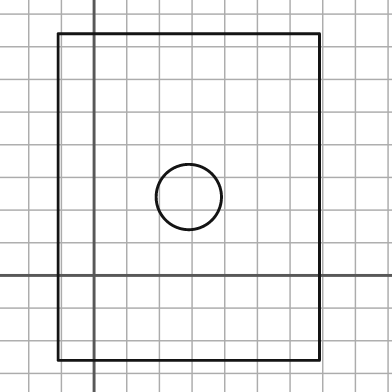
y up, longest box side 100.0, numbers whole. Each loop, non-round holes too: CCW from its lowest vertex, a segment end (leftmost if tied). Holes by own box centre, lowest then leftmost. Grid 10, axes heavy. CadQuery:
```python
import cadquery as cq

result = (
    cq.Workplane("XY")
    .moveTo(-11.0, -26.0)
    .lineTo(69.0, -26.0)
    .lineTo(69.0, 74.0)
    .lineTo(-11.0, 74.0)
    .close()
    .moveTo(29.0, 24.0)
    .circle(10.0)
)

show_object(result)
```